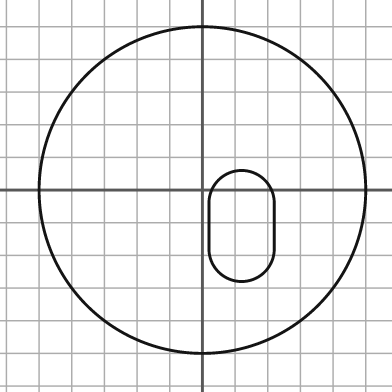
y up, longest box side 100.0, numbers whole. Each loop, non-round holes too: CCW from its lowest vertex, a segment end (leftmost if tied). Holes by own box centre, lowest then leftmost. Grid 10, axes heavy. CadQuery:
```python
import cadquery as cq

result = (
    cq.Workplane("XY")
    .moveTo(0.0, 0.0)
    .circle(50.0)
    .moveTo(2.0, -18.0)
    .threePointArc((12.0, -28.0), (22.0, -18.0))
    .lineTo(22.0, -4.0)
    .threePointArc((12.0, 6.0), (2.0, -4.0))
    .close()
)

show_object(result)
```